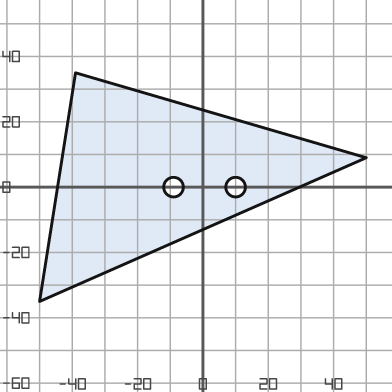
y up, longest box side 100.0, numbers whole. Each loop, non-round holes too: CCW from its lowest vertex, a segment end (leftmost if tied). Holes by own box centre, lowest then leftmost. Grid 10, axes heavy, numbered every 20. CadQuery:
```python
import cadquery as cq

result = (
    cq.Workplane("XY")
    .moveTo(-50.0, -35.0)
    .lineTo(50.0, 9.0)
    .lineTo(-39.0, 35.0)
    .close()
    .moveTo(-9.0, 0.0)
    .circle(3.0)
    .moveTo(10.0, 0.0)
    .circle(3.0)
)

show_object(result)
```